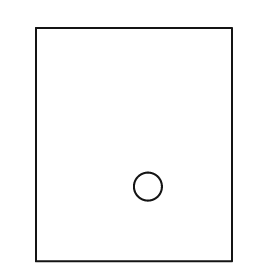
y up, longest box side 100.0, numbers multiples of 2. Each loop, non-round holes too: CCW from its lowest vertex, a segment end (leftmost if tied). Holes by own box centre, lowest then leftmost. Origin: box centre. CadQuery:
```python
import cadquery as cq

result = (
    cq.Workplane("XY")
    .moveTo(-42.0, -50.0)
    .lineTo(42.0, -50.0)
    .lineTo(42.0, 50.0)
    .lineTo(-42.0, 50.0)
    .close()
    .moveTo(6.0, -18.0)
    .circle(6.0)
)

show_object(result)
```